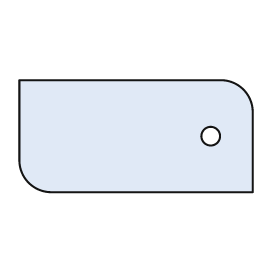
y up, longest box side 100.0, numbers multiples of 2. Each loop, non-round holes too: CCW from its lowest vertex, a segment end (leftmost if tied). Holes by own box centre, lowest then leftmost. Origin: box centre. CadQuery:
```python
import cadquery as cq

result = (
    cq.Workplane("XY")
    .moveTo(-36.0, -24.0)
    .lineTo(50.0, -24.0)
    .lineTo(50.0, 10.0)
    .threePointArc((46.0, 20.0), (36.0, 24.0))
    .lineTo(-50.0, 24.0)
    .lineTo(-50.0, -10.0)
    .threePointArc((-46.0, -20.0), (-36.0, -24.0))
    .close()
    .moveTo(32.0, 0.0)
    .circle(4.0)
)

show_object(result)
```